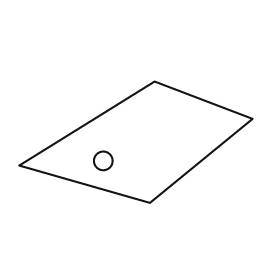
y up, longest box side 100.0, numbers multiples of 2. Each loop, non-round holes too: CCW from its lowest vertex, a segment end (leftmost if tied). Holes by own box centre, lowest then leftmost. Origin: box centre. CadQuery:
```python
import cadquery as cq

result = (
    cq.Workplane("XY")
    .moveTo(6.0, -26.0)
    .lineTo(50.0, 10.0)
    .lineTo(8.0, 26.0)
    .lineTo(-50.0, -10.0)
    .close()
    .moveTo(-14.0, -8.0)
    .circle(4.0)
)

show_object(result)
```